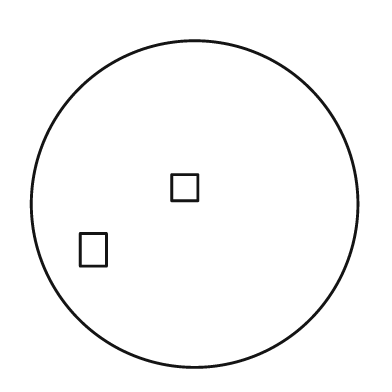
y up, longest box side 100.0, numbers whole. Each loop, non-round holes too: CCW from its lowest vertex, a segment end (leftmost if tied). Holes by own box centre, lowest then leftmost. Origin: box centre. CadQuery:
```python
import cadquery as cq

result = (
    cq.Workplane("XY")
    .moveTo(0.0, 0.0)
    .circle(50.0)
    .moveTo(-35.0, -19.0)
    .lineTo(-27.0, -19.0)
    .lineTo(-27.0, -9.0)
    .lineTo(-35.0, -9.0)
    .close()
    .moveTo(-7.0, 1.0)
    .lineTo(1.0, 1.0)
    .lineTo(1.0, 9.0)
    .lineTo(-7.0, 9.0)
    .close()
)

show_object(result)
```